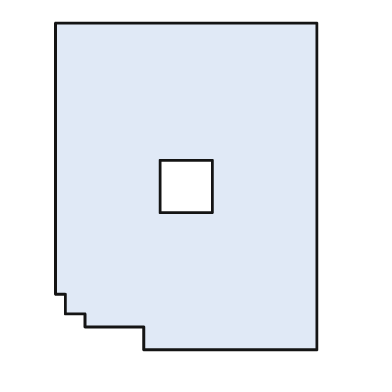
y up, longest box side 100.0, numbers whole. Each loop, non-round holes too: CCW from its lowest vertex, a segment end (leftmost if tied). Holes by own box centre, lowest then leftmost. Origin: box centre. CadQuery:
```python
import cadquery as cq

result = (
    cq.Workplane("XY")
    .moveTo(-13.0, -50.0)
    .lineTo(40.0, -50.0)
    .lineTo(40.0, 50.0)
    .lineTo(-40.0, 50.0)
    .lineTo(-40.0, -33.0)
    .lineTo(-37.0, -33.0)
    .lineTo(-37.0, -39.0)
    .lineTo(-31.0, -39.0)
    .lineTo(-31.0, -43.0)
    .lineTo(-13.0, -43.0)
    .close()
    .moveTo(-8.0, -8.0)
    .lineTo(8.0, -8.0)
    .lineTo(8.0, 8.0)
    .lineTo(-8.0, 8.0)
    .close()
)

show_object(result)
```